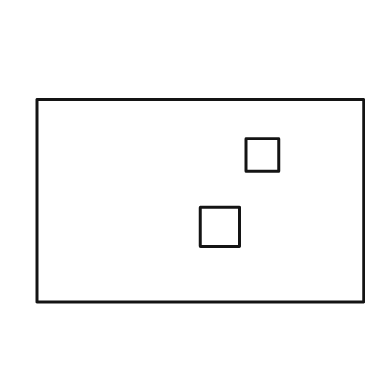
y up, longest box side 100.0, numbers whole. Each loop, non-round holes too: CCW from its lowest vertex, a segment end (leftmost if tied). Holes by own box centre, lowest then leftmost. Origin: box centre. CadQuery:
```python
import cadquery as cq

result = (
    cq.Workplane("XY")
    .moveTo(-50.0, -31.0)
    .lineTo(50.0, -31.0)
    .lineTo(50.0, 31.0)
    .lineTo(-50.0, 31.0)
    .close()
    .moveTo(0.0, -14.0)
    .lineTo(12.0, -14.0)
    .lineTo(12.0, -2.0)
    .lineTo(0.0, -2.0)
    .close()
    .moveTo(14.0, 9.0)
    .lineTo(24.0, 9.0)
    .lineTo(24.0, 19.0)
    .lineTo(14.0, 19.0)
    .close()
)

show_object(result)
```